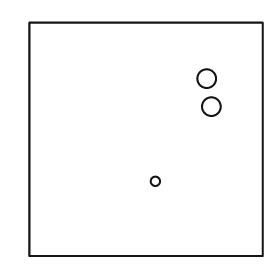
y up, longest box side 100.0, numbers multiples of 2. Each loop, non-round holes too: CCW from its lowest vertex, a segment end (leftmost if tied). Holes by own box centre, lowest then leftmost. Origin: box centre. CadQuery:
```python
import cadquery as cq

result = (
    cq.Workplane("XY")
    .moveTo(-50.0, -50.0)
    .lineTo(50.0, -50.0)
    .lineTo(50.0, 50.0)
    .lineTo(-50.0, 50.0)
    .close()
    .moveTo(4.0, -18.0)
    .circle(2.0)
    .moveTo(28.0, 14.0)
    .circle(4.0)
    .moveTo(26.0, 26.0)
    .circle(4.0)
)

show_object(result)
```